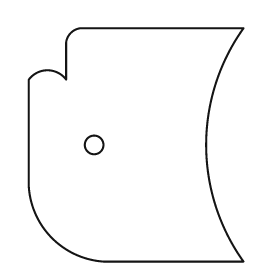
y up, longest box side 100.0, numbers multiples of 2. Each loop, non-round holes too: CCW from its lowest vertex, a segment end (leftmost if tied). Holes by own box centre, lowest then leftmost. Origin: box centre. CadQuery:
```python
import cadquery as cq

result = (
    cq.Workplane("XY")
    .moveTo(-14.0, -50.0)
    .lineTo(46.0, -50.0)
    .threePointArc((30.0, 0.0), (46.0, 50.0))
    .lineTo(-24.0, 50.0)
    .threePointArc((-28.0, 48.0), (-30.0, 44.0))
    .lineTo(-30.0, 28.0)
    .threePointArc((-38.0, 32.0), (-46.0, 28.0))
    .lineTo(-46.0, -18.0)
    .threePointArc((-36.0, -40.0), (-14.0, -50.0))
    .close()
    .moveTo(-18.0, 0.0)
    .circle(4.0)
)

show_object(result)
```